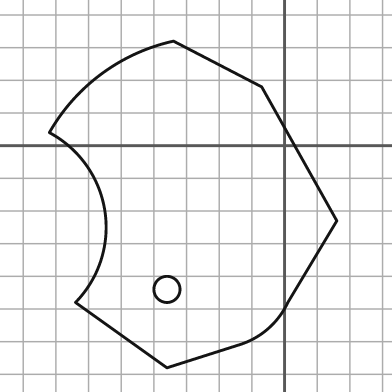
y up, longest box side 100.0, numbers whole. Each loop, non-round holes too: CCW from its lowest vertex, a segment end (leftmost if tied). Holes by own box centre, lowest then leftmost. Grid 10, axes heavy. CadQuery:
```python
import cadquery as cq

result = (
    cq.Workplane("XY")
    .moveTo(-36.0, -68.0)
    .lineTo(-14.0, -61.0)
    .threePointArc((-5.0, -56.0), (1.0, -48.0))
    .lineTo(16.0, -23.0)
    .lineTo(-7.0, 18.0)
    .lineTo(-34.0, 32.0)
    .threePointArc((-56.0, 22.0), (-72.0, 4.0))
    .threePointArc((-55.0, -20.0), (-64.0, -48.0))
    .close()
    .moveTo(-36.0, -44.0)
    .circle(4.0)
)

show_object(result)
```